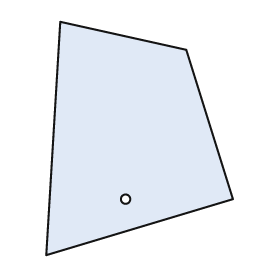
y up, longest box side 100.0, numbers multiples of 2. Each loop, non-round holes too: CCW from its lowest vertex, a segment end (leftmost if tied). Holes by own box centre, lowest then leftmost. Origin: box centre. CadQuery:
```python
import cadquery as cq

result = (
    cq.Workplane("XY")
    .moveTo(-40.0, -50.0)
    .lineTo(40.0, -26.0)
    .lineTo(20.0, 38.0)
    .lineTo(-34.0, 50.0)
    .close()
    .moveTo(-6.0, -26.0)
    .circle(2.0)
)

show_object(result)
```